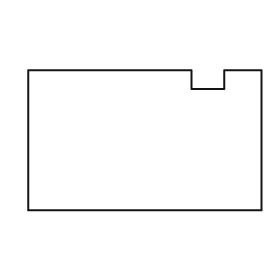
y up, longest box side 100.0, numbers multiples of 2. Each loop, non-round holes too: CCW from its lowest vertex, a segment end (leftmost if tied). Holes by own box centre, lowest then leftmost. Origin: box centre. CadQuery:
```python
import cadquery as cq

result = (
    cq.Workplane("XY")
    .moveTo(-50.0, -30.0)
    .lineTo(50.0, -30.0)
    .lineTo(50.0, 30.0)
    .lineTo(34.0, 30.0)
    .lineTo(34.0, 22.0)
    .lineTo(20.0, 22.0)
    .lineTo(20.0, 30.0)
    .lineTo(-50.0, 30.0)
    .close()
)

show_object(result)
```